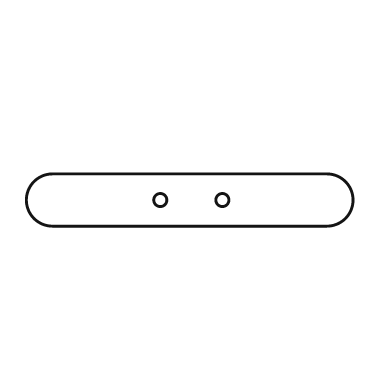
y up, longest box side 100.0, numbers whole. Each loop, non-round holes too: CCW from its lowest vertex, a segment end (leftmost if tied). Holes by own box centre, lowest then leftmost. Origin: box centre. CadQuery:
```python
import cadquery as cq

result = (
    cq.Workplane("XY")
    .moveTo(-42.0, -8.0)
    .lineTo(42.0, -8.0)
    .threePointArc((50.0, 0.0), (42.0, 8.0))
    .lineTo(-42.0, 8.0)
    .threePointArc((-50.0, 0.0), (-42.0, -8.0))
    .close()
    .moveTo(-9.0, 0.0)
    .circle(2.0)
    .moveTo(10.0, 0.0)
    .circle(2.0)
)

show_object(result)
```